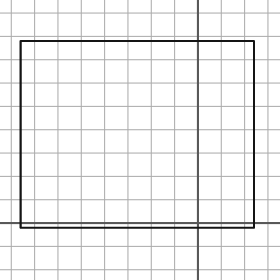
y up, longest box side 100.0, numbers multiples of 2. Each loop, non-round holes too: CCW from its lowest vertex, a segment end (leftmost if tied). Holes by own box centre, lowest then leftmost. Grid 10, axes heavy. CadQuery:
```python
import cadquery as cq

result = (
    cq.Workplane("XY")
    .moveTo(-76.0, -2.0)
    .lineTo(24.0, -2.0)
    .lineTo(24.0, 78.0)
    .lineTo(-76.0, 78.0)
    .close()
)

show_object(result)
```